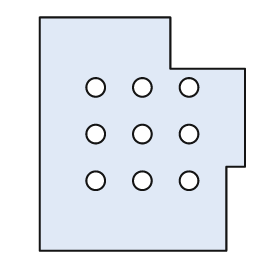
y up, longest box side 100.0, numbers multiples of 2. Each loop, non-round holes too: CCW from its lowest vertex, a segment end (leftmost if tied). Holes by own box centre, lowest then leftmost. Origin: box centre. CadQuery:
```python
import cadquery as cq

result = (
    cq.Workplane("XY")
    .moveTo(-44.0, -50.0)
    .lineTo(36.0, -50.0)
    .lineTo(36.0, -14.0)
    .lineTo(44.0, -14.0)
    .lineTo(44.0, 28.0)
    .lineTo(12.0, 28.0)
    .lineTo(12.0, 50.0)
    .lineTo(-44.0, 50.0)
    .close()
    .moveTo(-20.0, -20.0)
    .circle(4.0)
    .moveTo(0.0, -20.0)
    .circle(4.0)
    .moveTo(20.0, -20.0)
    .circle(4.0)
    .moveTo(-20.0, 0.0)
    .circle(4.0)
    .moveTo(0.0, 0.0)
    .circle(4.0)
    .moveTo(20.0, 0.0)
    .circle(4.0)
    .moveTo(-20.0, 20.0)
    .circle(4.0)
    .moveTo(0.0, 20.0)
    .circle(4.0)
    .moveTo(20.0, 20.0)
    .circle(4.0)
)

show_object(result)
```